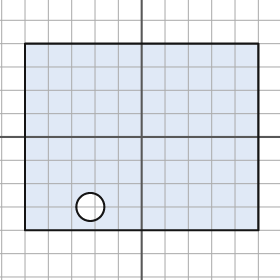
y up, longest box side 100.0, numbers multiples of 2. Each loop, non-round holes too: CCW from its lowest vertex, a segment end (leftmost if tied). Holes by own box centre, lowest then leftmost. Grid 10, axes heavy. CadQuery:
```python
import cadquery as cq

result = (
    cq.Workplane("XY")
    .moveTo(-50.0, -40.0)
    .lineTo(50.0, -40.0)
    .lineTo(50.0, 40.0)
    .lineTo(-50.0, 40.0)
    .close()
    .moveTo(-22.0, -30.0)
    .circle(6.0)
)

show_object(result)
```